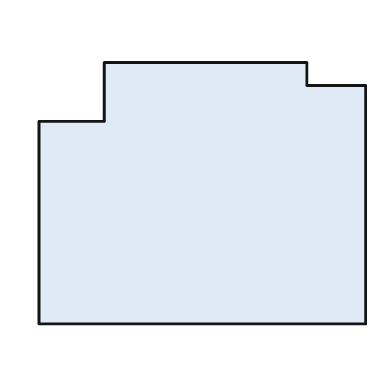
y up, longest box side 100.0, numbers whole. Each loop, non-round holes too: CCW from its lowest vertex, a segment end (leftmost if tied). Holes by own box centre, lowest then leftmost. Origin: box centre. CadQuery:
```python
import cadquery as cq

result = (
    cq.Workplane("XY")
    .moveTo(-50.0, -40.0)
    .lineTo(50.0, -40.0)
    .lineTo(50.0, 33.0)
    .lineTo(32.0, 33.0)
    .lineTo(32.0, 40.0)
    .lineTo(-30.0, 40.0)
    .lineTo(-30.0, 22.0)
    .lineTo(-50.0, 22.0)
    .close()
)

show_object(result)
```